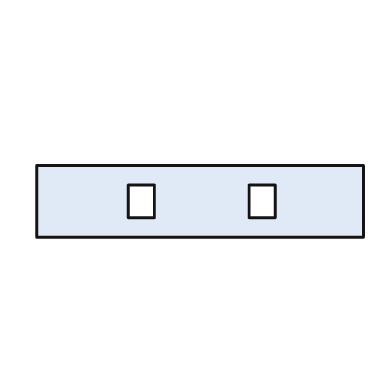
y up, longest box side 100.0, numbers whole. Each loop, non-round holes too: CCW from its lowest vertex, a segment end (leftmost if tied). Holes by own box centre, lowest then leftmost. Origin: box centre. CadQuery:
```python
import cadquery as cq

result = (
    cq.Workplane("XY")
    .moveTo(-50.0, -11.0)
    .lineTo(50.0, -11.0)
    .lineTo(50.0, 11.0)
    .lineTo(-50.0, 11.0)
    .close()
    .moveTo(-22.0, -5.0)
    .lineTo(-14.0, -5.0)
    .lineTo(-14.0, 5.0)
    .lineTo(-22.0, 5.0)
    .close()
    .moveTo(15.0, -5.0)
    .lineTo(23.0, -5.0)
    .lineTo(23.0, 5.0)
    .lineTo(15.0, 5.0)
    .close()
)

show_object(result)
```